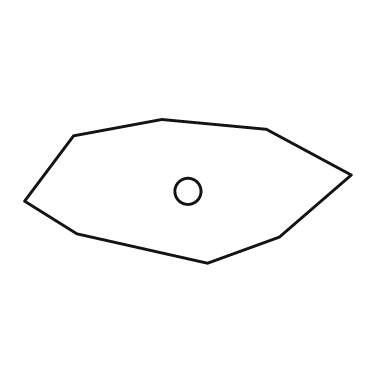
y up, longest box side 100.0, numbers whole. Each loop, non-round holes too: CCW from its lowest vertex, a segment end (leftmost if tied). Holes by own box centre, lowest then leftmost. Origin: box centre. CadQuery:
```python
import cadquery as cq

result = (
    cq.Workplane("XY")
    .moveTo(6.0, -22.0)
    .lineTo(28.0, -14.0)
    .lineTo(50.0, 5.0)
    .lineTo(24.0, 19.0)
    .lineTo(-8.0, 22.0)
    .lineTo(-35.0, 17.0)
    .lineTo(-50.0, -3.0)
    .lineTo(-34.0, -13.0)
    .close()
    .moveTo(0.0, 0.0)
    .circle(4.0)
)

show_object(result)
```